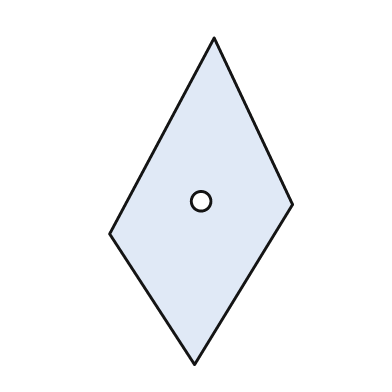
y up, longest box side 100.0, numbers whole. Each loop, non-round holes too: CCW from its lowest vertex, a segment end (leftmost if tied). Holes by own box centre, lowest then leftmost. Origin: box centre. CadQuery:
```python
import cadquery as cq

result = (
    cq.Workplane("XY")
    .moveTo(-2.0, -50.0)
    .lineTo(28.0, -1.0)
    .lineTo(4.0, 50.0)
    .lineTo(-28.0, -10.0)
    .close()
    .moveTo(0.0, 0.0)
    .circle(3.0)
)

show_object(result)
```